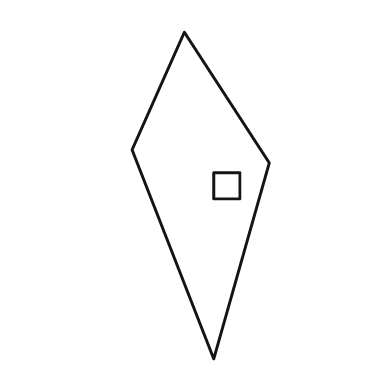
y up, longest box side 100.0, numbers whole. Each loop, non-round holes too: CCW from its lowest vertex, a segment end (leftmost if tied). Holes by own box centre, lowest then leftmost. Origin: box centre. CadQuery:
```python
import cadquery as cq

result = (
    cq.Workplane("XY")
    .moveTo(4.0, -50.0)
    .lineTo(21.0, 10.0)
    .lineTo(-5.0, 50.0)
    .lineTo(-21.0, 14.0)
    .close()
    .moveTo(4.0, -1.0)
    .lineTo(12.0, -1.0)
    .lineTo(12.0, 7.0)
    .lineTo(4.0, 7.0)
    .close()
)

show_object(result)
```